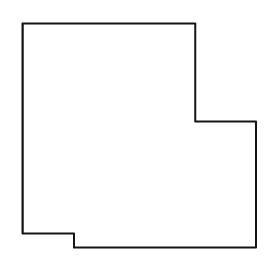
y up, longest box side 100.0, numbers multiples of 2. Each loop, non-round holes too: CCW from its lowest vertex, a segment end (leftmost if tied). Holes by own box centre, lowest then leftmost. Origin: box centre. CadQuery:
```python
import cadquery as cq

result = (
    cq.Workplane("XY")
    .moveTo(-28.0, -48.0)
    .lineTo(50.0, -48.0)
    .lineTo(50.0, 6.0)
    .lineTo(24.0, 6.0)
    .lineTo(24.0, 48.0)
    .lineTo(-50.0, 48.0)
    .lineTo(-50.0, -42.0)
    .lineTo(-28.0, -42.0)
    .close()
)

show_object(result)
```